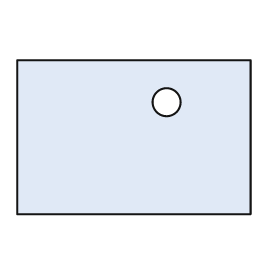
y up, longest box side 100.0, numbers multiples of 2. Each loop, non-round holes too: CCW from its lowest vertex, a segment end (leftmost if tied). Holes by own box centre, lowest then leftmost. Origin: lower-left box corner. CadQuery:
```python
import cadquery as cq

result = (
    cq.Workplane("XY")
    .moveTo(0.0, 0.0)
    .lineTo(100.0, 0.0)
    .lineTo(100.0, 66.0)
    .lineTo(0.0, 66.0)
    .close()
    .moveTo(64.0, 48.0)
    .circle(6.0)
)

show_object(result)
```